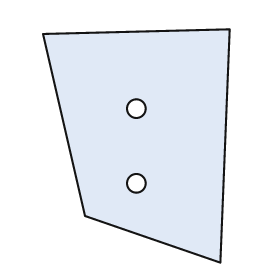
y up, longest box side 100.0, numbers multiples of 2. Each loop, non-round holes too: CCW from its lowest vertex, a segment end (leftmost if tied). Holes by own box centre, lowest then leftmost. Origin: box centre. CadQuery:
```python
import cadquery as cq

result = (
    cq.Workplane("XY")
    .moveTo(36.0, -50.0)
    .lineTo(40.0, 50.0)
    .lineTo(-40.0, 48.0)
    .lineTo(-22.0, -30.0)
    .close()
    .moveTo(0.0, -16.0)
    .circle(4.0)
    .moveTo(0.0, 16.0)
    .circle(4.0)
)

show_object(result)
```